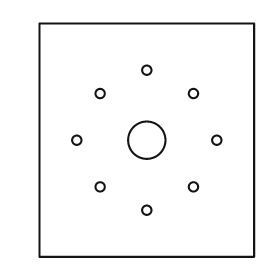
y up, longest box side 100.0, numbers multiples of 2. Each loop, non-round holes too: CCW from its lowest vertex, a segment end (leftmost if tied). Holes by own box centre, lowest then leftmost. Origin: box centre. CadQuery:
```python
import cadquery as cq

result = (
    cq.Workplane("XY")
    .moveTo(-46.0, -50.0)
    .lineTo(46.0, -50.0)
    .lineTo(46.0, 50.0)
    .lineTo(-46.0, 50.0)
    .close()
    .moveTo(0.0, -30.0)
    .circle(2.0)
    .moveTo(-20.0, -20.0)
    .circle(2.0)
    .moveTo(20.0, -20.0)
    .circle(2.0)
    .moveTo(-30.0, 0.0)
    .circle(2.0)
    .moveTo(0.0, 0.0)
    .circle(8.0)
    .moveTo(30.0, 0.0)
    .circle(2.0)
    .moveTo(-20.0, 20.0)
    .circle(2.0)
    .moveTo(20.0, 20.0)
    .circle(2.0)
    .moveTo(0.0, 30.0)
    .circle(2.0)
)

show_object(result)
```